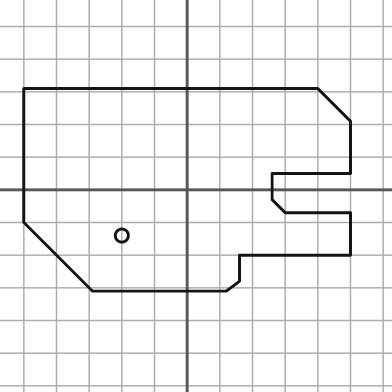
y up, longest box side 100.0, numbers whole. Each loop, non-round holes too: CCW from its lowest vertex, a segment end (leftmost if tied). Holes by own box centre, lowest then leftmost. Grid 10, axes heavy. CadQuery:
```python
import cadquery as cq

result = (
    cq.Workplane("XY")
    .moveTo(-29.0, -31.0)
    .lineTo(12.0, -31.0)
    .lineTo(16.0, -28.0)
    .lineTo(16.0, -20.0)
    .lineTo(50.0, -20.0)
    .lineTo(50.0, -7.0)
    .lineTo(30.0, -7.0)
    .lineTo(26.0, -3.0)
    .lineTo(26.0, 5.0)
    .lineTo(50.0, 5.0)
    .lineTo(50.0, 21.0)
    .lineTo(40.0, 31.0)
    .lineTo(-50.0, 31.0)
    .lineTo(-50.0, -10.0)
    .close()
    .moveTo(-20.0, -14.0)
    .circle(2.0)
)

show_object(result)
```